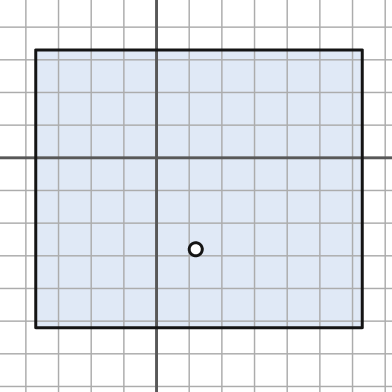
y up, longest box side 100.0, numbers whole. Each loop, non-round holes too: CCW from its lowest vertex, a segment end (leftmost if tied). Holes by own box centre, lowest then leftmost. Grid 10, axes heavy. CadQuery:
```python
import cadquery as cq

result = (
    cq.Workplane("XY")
    .moveTo(-37.0, -52.0)
    .lineTo(63.0, -52.0)
    .lineTo(63.0, 33.0)
    .lineTo(-37.0, 33.0)
    .close()
    .moveTo(12.0, -28.0)
    .circle(2.0)
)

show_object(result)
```